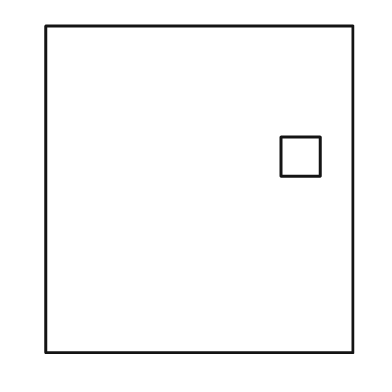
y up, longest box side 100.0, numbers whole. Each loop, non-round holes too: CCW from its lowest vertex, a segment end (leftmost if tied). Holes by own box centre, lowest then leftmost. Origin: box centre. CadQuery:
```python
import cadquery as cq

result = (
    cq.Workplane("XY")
    .moveTo(-47.0, -50.0)
    .lineTo(47.0, -50.0)
    .lineTo(47.0, 50.0)
    .lineTo(-47.0, 50.0)
    .close()
    .moveTo(25.0, 4.0)
    .lineTo(37.0, 4.0)
    .lineTo(37.0, 16.0)
    .lineTo(25.0, 16.0)
    .close()
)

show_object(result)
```